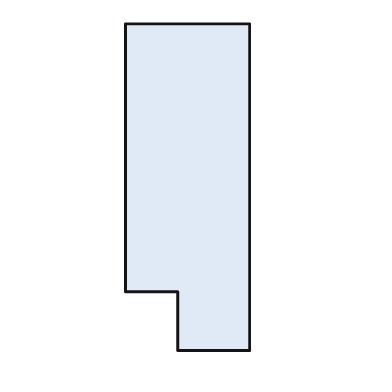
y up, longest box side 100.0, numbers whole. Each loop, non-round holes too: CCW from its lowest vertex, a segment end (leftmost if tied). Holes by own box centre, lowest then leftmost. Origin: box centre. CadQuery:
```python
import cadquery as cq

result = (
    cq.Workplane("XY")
    .moveTo(-3.0, -50.0)
    .lineTo(19.0, -50.0)
    .lineTo(19.0, 50.0)
    .lineTo(-19.0, 50.0)
    .lineTo(-19.0, -32.0)
    .lineTo(-3.0, -32.0)
    .close()
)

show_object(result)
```